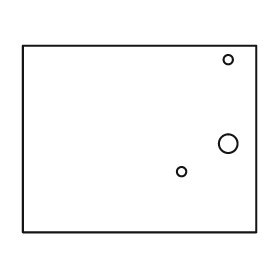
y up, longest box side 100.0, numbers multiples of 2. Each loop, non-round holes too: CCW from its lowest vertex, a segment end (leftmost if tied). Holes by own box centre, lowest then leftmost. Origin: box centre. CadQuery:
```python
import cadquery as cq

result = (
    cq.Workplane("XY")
    .moveTo(-50.0, -40.0)
    .lineTo(50.0, -40.0)
    .lineTo(50.0, 40.0)
    .lineTo(-50.0, 40.0)
    .close()
    .moveTo(18.0, -14.0)
    .circle(2.0)
    .moveTo(38.0, -2.0)
    .circle(4.0)
    .moveTo(38.0, 34.0)
    .circle(2.0)
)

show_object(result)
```